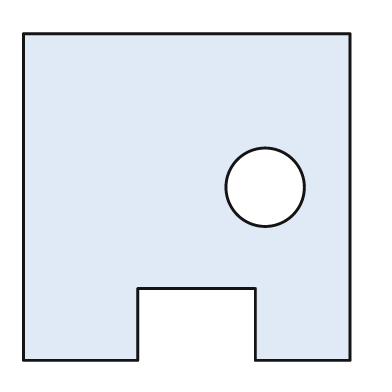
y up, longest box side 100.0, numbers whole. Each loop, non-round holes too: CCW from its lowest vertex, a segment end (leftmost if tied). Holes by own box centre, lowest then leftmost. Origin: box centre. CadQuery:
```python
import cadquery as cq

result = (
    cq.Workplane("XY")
    .moveTo(-50.0, -50.0)
    .lineTo(-15.0, -50.0)
    .lineTo(-15.0, -28.0)
    .lineTo(21.0, -28.0)
    .lineTo(21.0, -50.0)
    .lineTo(50.0, -50.0)
    .lineTo(50.0, 50.0)
    .lineTo(-50.0, 50.0)
    .close()
    .moveTo(24.0, 3.0)
    .circle(12.0)
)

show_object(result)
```